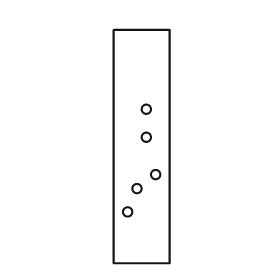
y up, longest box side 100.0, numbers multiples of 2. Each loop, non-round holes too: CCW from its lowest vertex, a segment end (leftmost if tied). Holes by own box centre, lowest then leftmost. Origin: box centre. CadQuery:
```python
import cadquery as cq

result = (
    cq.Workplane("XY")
    .moveTo(-12.0, -50.0)
    .lineTo(12.0, -50.0)
    .lineTo(12.0, 50.0)
    .lineTo(-12.0, 50.0)
    .close()
    .moveTo(-6.0, -28.0)
    .circle(2.0)
    .moveTo(-2.0, -18.0)
    .circle(2.0)
    .moveTo(6.0, -12.0)
    .circle(2.0)
    .moveTo(2.0, 4.0)
    .circle(2.0)
    .moveTo(2.0, 16.0)
    .circle(2.0)
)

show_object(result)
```